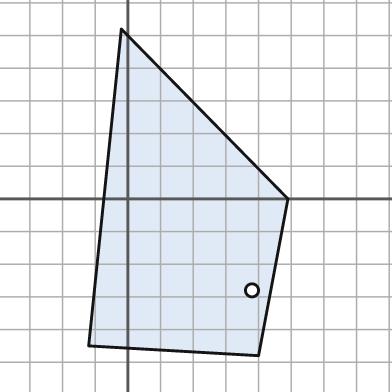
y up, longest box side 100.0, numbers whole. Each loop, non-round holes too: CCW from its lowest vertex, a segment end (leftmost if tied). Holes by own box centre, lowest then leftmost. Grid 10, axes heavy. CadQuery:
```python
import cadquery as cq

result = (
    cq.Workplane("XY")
    .moveTo(40.0, -48.0)
    .lineTo(49.0, 0.0)
    .lineTo(-2.0, 52.0)
    .lineTo(-12.0, -45.0)
    .close()
    .moveTo(38.0, -28.0)
    .circle(2.0)
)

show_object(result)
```